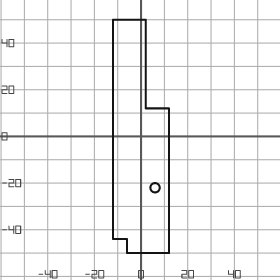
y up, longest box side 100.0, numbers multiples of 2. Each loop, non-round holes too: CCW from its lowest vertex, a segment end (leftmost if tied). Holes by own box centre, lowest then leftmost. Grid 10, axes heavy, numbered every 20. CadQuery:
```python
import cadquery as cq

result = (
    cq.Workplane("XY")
    .moveTo(-6.0, -50.0)
    .lineTo(12.0, -50.0)
    .lineTo(12.0, 12.0)
    .lineTo(2.0, 12.0)
    .lineTo(2.0, 50.0)
    .lineTo(-12.0, 50.0)
    .lineTo(-12.0, -44.0)
    .lineTo(-6.0, -44.0)
    .close()
    .moveTo(6.0, -22.0)
    .circle(2.0)
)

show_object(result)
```